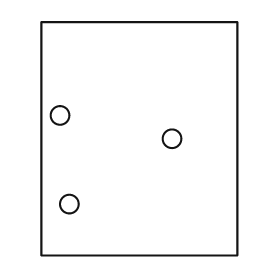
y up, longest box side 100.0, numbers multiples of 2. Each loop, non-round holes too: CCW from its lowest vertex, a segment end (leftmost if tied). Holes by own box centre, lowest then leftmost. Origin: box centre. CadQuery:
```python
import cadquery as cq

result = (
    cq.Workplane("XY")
    .moveTo(-42.0, -50.0)
    .lineTo(42.0, -50.0)
    .lineTo(42.0, 50.0)
    .lineTo(-42.0, 50.0)
    .close()
    .moveTo(-30.0, -28.0)
    .circle(4.0)
    .moveTo(14.0, 0.0)
    .circle(4.0)
    .moveTo(-34.0, 10.0)
    .circle(4.0)
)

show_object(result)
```